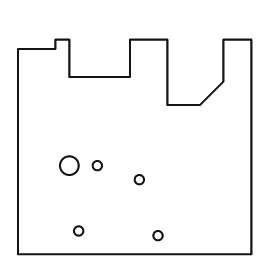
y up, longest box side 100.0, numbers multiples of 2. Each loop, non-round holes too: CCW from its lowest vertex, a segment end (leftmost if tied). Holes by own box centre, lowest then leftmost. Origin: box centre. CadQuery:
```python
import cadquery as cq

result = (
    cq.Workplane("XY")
    .moveTo(-50.0, -46.0)
    .lineTo(50.0, -46.0)
    .lineTo(50.0, 46.0)
    .lineTo(38.0, 46.0)
    .lineTo(38.0, 28.0)
    .lineTo(28.0, 18.0)
    .lineTo(14.0, 18.0)
    .lineTo(14.0, 46.0)
    .lineTo(-2.0, 46.0)
    .lineTo(-2.0, 30.0)
    .lineTo(-28.0, 30.0)
    .lineTo(-28.0, 46.0)
    .lineTo(-34.0, 46.0)
    .lineTo(-34.0, 42.0)
    .lineTo(-50.0, 42.0)
    .close()
    .moveTo(10.0, -38.0)
    .circle(2.0)
    .moveTo(-24.0, -36.0)
    .circle(2.0)
    .moveTo(2.0, -14.0)
    .circle(2.0)
    .moveTo(-28.0, -8.0)
    .circle(4.0)
    .moveTo(-16.0, -8.0)
    .circle(2.0)
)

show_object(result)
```